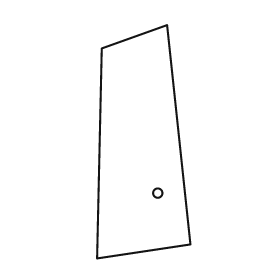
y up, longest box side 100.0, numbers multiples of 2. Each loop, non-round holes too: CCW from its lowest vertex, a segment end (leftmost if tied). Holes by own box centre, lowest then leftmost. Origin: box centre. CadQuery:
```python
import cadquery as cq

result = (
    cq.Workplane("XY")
    .moveTo(-20.0, -50.0)
    .lineTo(20.0, -44.0)
    .lineTo(10.0, 50.0)
    .lineTo(-18.0, 40.0)
    .close()
    .moveTo(6.0, -22.0)
    .circle(2.0)
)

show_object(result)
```